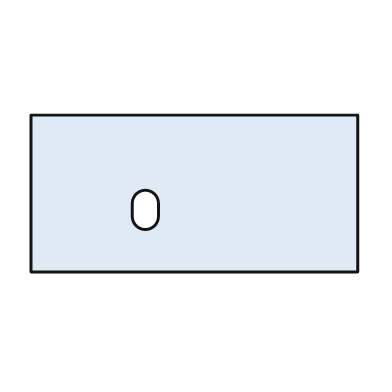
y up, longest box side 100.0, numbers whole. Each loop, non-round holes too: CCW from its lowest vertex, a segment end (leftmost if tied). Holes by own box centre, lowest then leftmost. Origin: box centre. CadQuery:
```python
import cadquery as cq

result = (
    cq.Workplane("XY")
    .moveTo(-50.0, -24.0)
    .lineTo(50.0, -24.0)
    .lineTo(50.0, 24.0)
    .lineTo(-50.0, 24.0)
    .close()
    .moveTo(-19.0, -7.0)
    .threePointArc((-15.0, -11.0), (-11.0, -7.0))
    .lineTo(-11.0, -3.0)
    .threePointArc((-15.0, 1.0), (-19.0, -3.0))
    .close()
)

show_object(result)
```